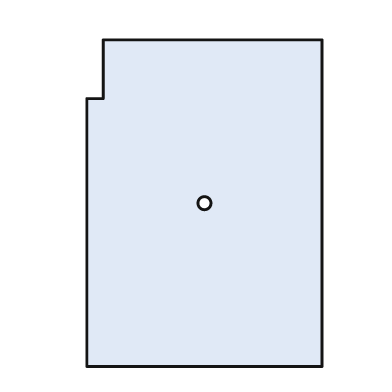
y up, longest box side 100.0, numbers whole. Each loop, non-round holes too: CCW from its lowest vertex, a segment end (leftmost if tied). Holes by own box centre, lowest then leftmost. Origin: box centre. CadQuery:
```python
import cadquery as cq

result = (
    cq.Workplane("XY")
    .moveTo(-36.0, -50.0)
    .lineTo(36.0, -50.0)
    .lineTo(36.0, 50.0)
    .lineTo(-31.0, 50.0)
    .lineTo(-31.0, 32.0)
    .lineTo(-36.0, 32.0)
    .close()
    .moveTo(0.0, 0.0)
    .circle(2.0)
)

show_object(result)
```